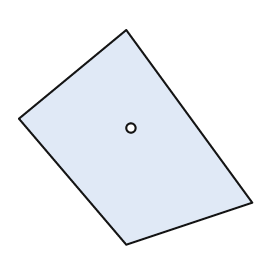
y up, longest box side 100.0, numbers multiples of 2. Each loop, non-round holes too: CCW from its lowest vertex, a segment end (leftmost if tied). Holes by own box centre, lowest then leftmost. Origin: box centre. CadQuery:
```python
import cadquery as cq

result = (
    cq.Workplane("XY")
    .moveTo(-4.0, -46.0)
    .lineTo(50.0, -28.0)
    .lineTo(-4.0, 46.0)
    .lineTo(-50.0, 8.0)
    .close()
    .moveTo(-2.0, 4.0)
    .circle(2.0)
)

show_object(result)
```